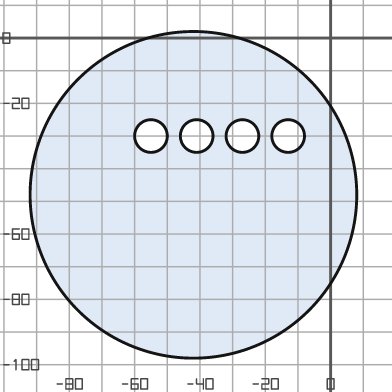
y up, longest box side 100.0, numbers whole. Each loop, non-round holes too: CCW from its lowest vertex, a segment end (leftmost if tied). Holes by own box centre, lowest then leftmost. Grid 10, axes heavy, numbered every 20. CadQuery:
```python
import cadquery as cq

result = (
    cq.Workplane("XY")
    .moveTo(-42.0, -48.0)
    .circle(50.0)
    .moveTo(-55.0, -30.0)
    .circle(5.0)
    .moveTo(-41.0, -30.0)
    .circle(5.0)
    .moveTo(-27.0, -30.0)
    .circle(5.0)
    .moveTo(-13.0, -30.0)
    .circle(5.0)
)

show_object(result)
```